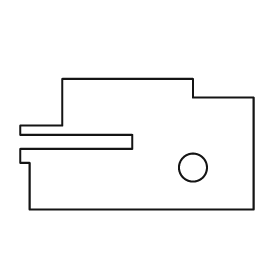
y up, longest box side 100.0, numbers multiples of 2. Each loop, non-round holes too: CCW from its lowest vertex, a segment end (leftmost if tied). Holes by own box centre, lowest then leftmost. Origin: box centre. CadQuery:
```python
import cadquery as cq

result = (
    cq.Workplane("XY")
    .moveTo(-46.0, -28.0)
    .lineTo(50.0, -28.0)
    .lineTo(50.0, 20.0)
    .lineTo(24.0, 20.0)
    .lineTo(24.0, 28.0)
    .lineTo(-32.0, 28.0)
    .lineTo(-32.0, 8.0)
    .lineTo(-50.0, 8.0)
    .lineTo(-50.0, 4.0)
    .lineTo(-2.0, 4.0)
    .lineTo(-2.0, -2.0)
    .lineTo(-50.0, -2.0)
    .lineTo(-50.0, -8.0)
    .lineTo(-46.0, -8.0)
    .close()
    .moveTo(24.0, -10.0)
    .circle(6.0)
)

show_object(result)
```